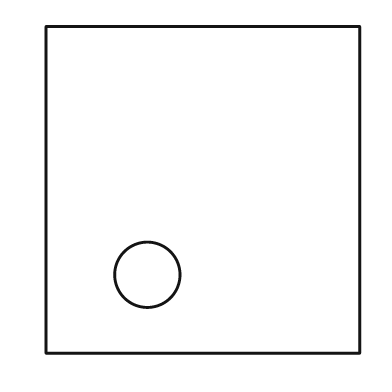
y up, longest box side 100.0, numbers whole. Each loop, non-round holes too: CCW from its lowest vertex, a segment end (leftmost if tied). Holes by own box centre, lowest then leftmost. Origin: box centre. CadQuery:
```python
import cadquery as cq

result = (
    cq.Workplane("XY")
    .moveTo(-48.0, -50.0)
    .lineTo(48.0, -50.0)
    .lineTo(48.0, 50.0)
    .lineTo(-48.0, 50.0)
    .close()
    .moveTo(-17.0, -26.0)
    .circle(10.0)
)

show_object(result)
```